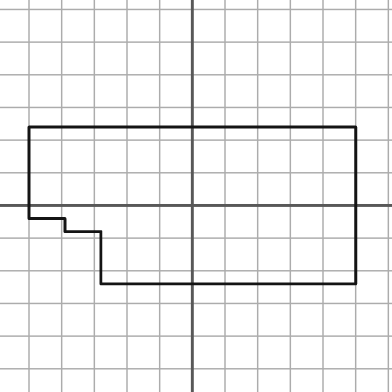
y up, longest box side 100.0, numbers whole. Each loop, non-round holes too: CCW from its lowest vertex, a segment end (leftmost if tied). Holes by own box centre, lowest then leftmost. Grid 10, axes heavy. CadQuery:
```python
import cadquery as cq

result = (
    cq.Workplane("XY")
    .moveTo(-28.0, -24.0)
    .lineTo(50.0, -24.0)
    .lineTo(50.0, 24.0)
    .lineTo(-50.0, 24.0)
    .lineTo(-50.0, -4.0)
    .lineTo(-39.0, -4.0)
    .lineTo(-39.0, -8.0)
    .lineTo(-28.0, -8.0)
    .close()
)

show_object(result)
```